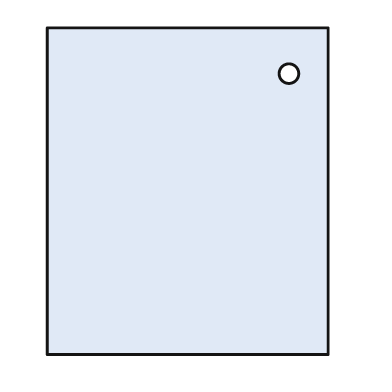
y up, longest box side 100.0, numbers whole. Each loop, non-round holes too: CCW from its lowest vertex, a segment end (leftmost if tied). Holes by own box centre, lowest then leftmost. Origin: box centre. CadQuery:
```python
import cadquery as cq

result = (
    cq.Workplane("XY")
    .moveTo(-43.0, -50.0)
    .lineTo(43.0, -50.0)
    .lineTo(43.0, 50.0)
    .lineTo(-43.0, 50.0)
    .close()
    .moveTo(31.0, 36.0)
    .circle(3.0)
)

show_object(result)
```